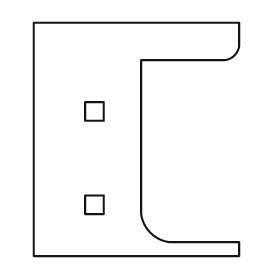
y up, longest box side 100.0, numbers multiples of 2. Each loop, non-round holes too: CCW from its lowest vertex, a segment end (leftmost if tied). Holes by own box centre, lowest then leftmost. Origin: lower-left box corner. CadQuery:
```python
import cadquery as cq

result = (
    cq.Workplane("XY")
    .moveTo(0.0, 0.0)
    .lineTo(88.0, 0.0)
    .lineTo(88.0, 6.0)
    .lineTo(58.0, 6.0)
    .threePointArc((50.0, 10.0), (46.0, 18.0))
    .lineTo(46.0, 84.0)
    .lineTo(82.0, 84.0)
    .threePointArc((86.0, 86.0), (88.0, 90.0))
    .lineTo(88.0, 100.0)
    .lineTo(0.0, 100.0)
    .close()
    .moveTo(22.0, 18.0)
    .lineTo(30.0, 18.0)
    .lineTo(30.0, 26.0)
    .lineTo(22.0, 26.0)
    .close()
    .moveTo(22.0, 58.0)
    .lineTo(30.0, 58.0)
    .lineTo(30.0, 66.0)
    .lineTo(22.0, 66.0)
    .close()
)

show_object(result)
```